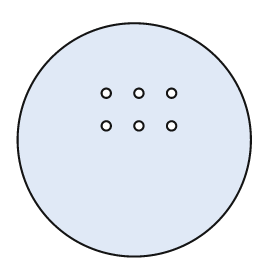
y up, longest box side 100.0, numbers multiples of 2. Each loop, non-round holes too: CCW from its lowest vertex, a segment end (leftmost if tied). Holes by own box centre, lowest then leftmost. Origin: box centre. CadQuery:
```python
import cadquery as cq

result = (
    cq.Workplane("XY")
    .moveTo(0.0, 0.0)
    .circle(50.0)
    .moveTo(-12.0, 6.0)
    .circle(2.0)
    .moveTo(2.0, 6.0)
    .circle(2.0)
    .moveTo(16.0, 6.0)
    .circle(2.0)
    .moveTo(-12.0, 20.0)
    .circle(2.0)
    .moveTo(2.0, 20.0)
    .circle(2.0)
    .moveTo(16.0, 20.0)
    .circle(2.0)
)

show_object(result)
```